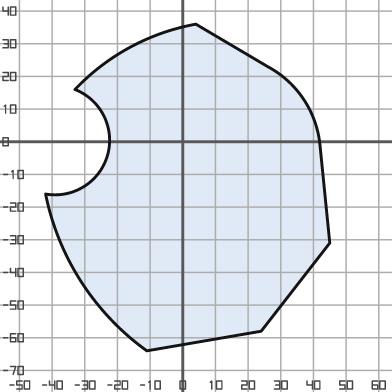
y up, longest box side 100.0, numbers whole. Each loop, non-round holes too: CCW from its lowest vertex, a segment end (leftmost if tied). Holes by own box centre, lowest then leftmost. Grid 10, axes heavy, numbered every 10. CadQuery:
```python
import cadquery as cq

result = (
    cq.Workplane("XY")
    .moveTo(-11.0, -64.0)
    .lineTo(24.0, -58.0)
    .lineTo(45.0, -31.0)
    .lineTo(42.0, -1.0)
    .threePointArc((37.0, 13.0), (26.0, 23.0))
    .lineTo(4.0, 36.0)
    .threePointArc((-16.0, 29.0), (-33.0, 16.0))
    .threePointArc((-23.0, -4.0), (-42.0, -16.0))
    .threePointArc((-31.0, -43.0), (-11.0, -64.0))
    .close()
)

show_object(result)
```